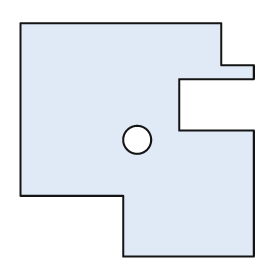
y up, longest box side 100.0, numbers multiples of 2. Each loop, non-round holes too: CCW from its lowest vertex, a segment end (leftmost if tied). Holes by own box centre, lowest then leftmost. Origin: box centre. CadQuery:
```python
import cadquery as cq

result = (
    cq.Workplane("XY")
    .moveTo(-6.0, -50.0)
    .lineTo(50.0, -50.0)
    .lineTo(50.0, 4.0)
    .lineTo(18.0, 4.0)
    .lineTo(18.0, 26.0)
    .lineTo(50.0, 26.0)
    .lineTo(50.0, 32.0)
    .lineTo(36.0, 32.0)
    .lineTo(36.0, 50.0)
    .lineTo(-50.0, 50.0)
    .lineTo(-50.0, -24.0)
    .lineTo(-6.0, -24.0)
    .close()
    .moveTo(0.0, 0.0)
    .circle(6.0)
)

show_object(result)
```